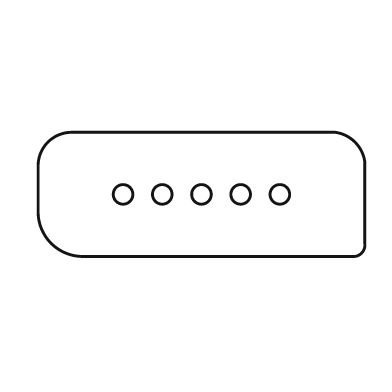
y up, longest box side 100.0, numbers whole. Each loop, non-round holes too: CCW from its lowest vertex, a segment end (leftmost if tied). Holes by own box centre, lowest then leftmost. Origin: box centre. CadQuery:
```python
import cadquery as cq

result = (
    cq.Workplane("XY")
    .moveTo(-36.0, -19.0)
    .lineTo(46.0, -19.0)
    .threePointArc((49.0, -18.0), (50.0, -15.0))
    .lineTo(50.0, 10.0)
    .threePointArc((47.0, 16.0), (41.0, 19.0))
    .lineTo(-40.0, 19.0)
    .threePointArc((-47.0, 16.0), (-50.0, 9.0))
    .lineTo(-50.0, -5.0)
    .threePointArc((-46.0, -15.0), (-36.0, -19.0))
    .close()
    .moveTo(-24.0, 0.0)
    .circle(3.0)
    .moveTo(-12.0, 0.0)
    .circle(3.0)
    .moveTo(0.0, 0.0)
    .circle(3.0)
    .moveTo(12.0, 0.0)
    .circle(3.0)
    .moveTo(24.0, 0.0)
    .circle(3.0)
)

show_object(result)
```